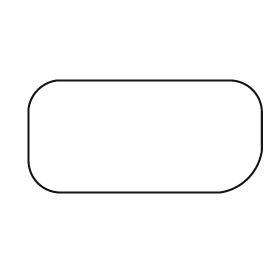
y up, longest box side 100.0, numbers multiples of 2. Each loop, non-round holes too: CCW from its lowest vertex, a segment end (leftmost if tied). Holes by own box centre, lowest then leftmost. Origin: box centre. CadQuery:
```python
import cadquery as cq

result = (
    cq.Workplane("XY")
    .moveTo(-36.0, -24.0)
    .lineTo(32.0, -24.0)
    .threePointArc((44.0, -18.0), (50.0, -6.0))
    .lineTo(50.0, 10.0)
    .threePointArc((46.0, 20.0), (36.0, 24.0))
    .lineTo(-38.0, 24.0)
    .threePointArc((-46.0, 20.0), (-50.0, 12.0))
    .lineTo(-50.0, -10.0)
    .threePointArc((-46.0, -20.0), (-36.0, -24.0))
    .close()
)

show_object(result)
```